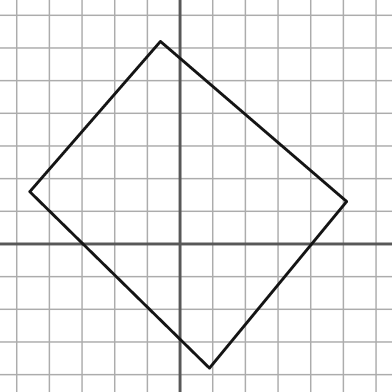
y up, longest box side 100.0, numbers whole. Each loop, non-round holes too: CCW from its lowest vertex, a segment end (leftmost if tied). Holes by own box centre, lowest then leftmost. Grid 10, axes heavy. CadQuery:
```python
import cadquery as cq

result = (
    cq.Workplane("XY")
    .moveTo(9.0, -38.0)
    .lineTo(51.0, 13.0)
    .lineTo(-6.0, 62.0)
    .lineTo(-46.0, 16.0)
    .close()
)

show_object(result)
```